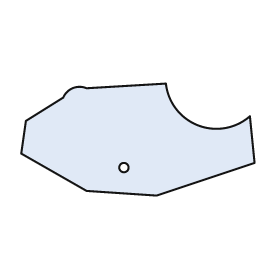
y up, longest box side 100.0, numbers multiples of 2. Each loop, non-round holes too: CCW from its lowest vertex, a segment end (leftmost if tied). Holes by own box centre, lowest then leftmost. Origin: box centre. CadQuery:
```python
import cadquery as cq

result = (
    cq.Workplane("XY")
    .moveTo(8.0, -24.0)
    .lineTo(50.0, -10.0)
    .lineTo(48.0, 10.0)
    .threePointArc((26.0, 6.0), (12.0, 24.0))
    .lineTo(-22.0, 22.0)
    .threePointArc((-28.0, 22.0), (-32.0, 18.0))
    .lineTo(-48.0, 8.0)
    .lineTo(-50.0, -6.0)
    .lineTo(-22.0, -22.0)
    .close()
    .moveTo(-6.0, -12.0)
    .circle(2.0)
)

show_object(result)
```